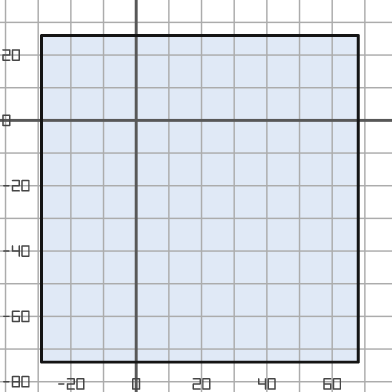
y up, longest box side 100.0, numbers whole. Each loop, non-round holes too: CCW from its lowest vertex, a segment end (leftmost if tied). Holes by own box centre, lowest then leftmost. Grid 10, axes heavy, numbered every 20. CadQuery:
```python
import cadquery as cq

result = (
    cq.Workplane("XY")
    .moveTo(-29.0, -74.0)
    .lineTo(68.0, -74.0)
    .lineTo(68.0, 26.0)
    .lineTo(-29.0, 26.0)
    .close()
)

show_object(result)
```